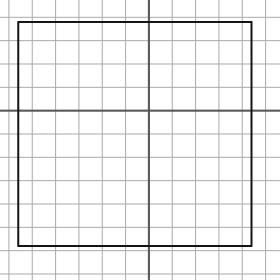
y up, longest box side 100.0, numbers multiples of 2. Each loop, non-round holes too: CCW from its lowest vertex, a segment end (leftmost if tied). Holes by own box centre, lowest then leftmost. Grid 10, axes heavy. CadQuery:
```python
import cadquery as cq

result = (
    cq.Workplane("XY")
    .moveTo(-56.0, -58.0)
    .lineTo(44.0, -58.0)
    .lineTo(44.0, 38.0)
    .lineTo(-56.0, 38.0)
    .close()
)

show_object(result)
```